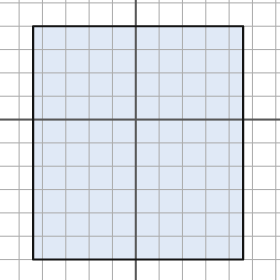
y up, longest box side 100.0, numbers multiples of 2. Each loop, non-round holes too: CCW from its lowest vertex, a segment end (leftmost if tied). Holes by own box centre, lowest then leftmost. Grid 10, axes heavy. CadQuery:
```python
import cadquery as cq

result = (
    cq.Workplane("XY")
    .moveTo(-44.0, -60.0)
    .lineTo(46.0, -60.0)
    .lineTo(46.0, 40.0)
    .lineTo(-44.0, 40.0)
    .close()
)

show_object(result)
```